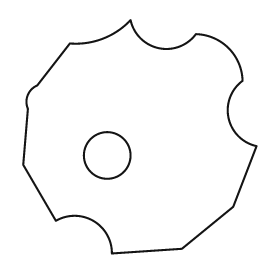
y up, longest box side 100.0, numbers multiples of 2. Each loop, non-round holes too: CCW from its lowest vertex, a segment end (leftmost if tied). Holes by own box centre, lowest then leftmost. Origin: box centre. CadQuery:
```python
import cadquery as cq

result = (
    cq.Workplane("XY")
    .moveTo(-12.0, -50.0)
    .lineTo(18.0, -48.0)
    .lineTo(40.0, -30.0)
    .lineTo(50.0, -4.0)
    .threePointArc((38.0, 8.0), (44.0, 24.0))
    .threePointArc((38.0, 38.0), (24.0, 44.0))
    .threePointArc((8.0, 38.0), (-4.0, 50.0))
    .threePointArc((-16.0, 42.0), (-30.0, 40.0))
    .lineTo(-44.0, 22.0)
    .threePointArc((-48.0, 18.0), (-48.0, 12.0))
    .lineTo(-50.0, -12.0)
    .lineTo(-36.0, -36.0)
    .threePointArc((-20.0, -36.0), (-12.0, -50.0))
    .close()
    .moveTo(-14.0, -8.0)
    .circle(10.0)
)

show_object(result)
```